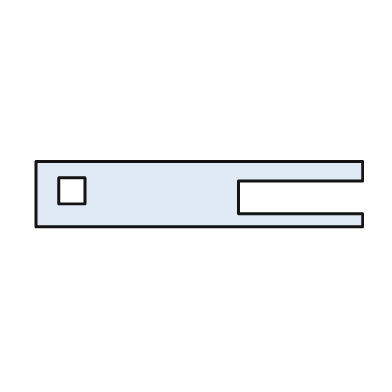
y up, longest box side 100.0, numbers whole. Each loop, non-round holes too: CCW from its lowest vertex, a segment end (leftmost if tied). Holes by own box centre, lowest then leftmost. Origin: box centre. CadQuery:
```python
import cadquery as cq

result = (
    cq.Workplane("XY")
    .moveTo(-50.0, -10.0)
    .lineTo(50.0, -10.0)
    .lineTo(50.0, -6.0)
    .lineTo(12.0, -6.0)
    .lineTo(12.0, 4.0)
    .lineTo(50.0, 4.0)
    .lineTo(50.0, 10.0)
    .lineTo(-50.0, 10.0)
    .close()
    .moveTo(-43.0, -3.0)
    .lineTo(-35.0, -3.0)
    .lineTo(-35.0, 5.0)
    .lineTo(-43.0, 5.0)
    .close()
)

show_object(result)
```